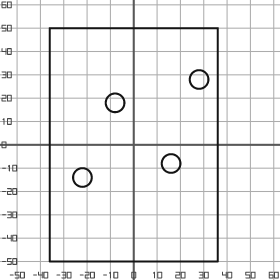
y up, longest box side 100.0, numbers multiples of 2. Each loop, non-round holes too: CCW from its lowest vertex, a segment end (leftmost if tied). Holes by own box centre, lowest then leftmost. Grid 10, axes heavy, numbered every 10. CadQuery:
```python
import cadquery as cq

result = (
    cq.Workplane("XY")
    .moveTo(-36.0, -50.0)
    .lineTo(36.0, -50.0)
    .lineTo(36.0, 50.0)
    .lineTo(-36.0, 50.0)
    .close()
    .moveTo(-22.0, -14.0)
    .circle(4.0)
    .moveTo(16.0, -8.0)
    .circle(4.0)
    .moveTo(-8.0, 18.0)
    .circle(4.0)
    .moveTo(28.0, 28.0)
    .circle(4.0)
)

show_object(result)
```